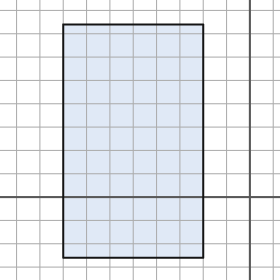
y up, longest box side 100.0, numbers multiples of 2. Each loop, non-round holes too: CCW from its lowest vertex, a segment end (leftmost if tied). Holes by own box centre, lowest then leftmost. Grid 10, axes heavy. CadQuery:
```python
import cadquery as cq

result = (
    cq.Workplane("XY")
    .moveTo(-80.0, -26.0)
    .lineTo(-20.0, -26.0)
    .lineTo(-20.0, 74.0)
    .lineTo(-80.0, 74.0)
    .close()
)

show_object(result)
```